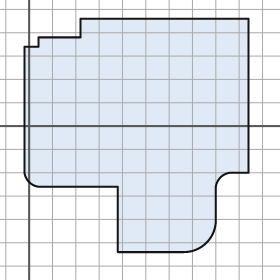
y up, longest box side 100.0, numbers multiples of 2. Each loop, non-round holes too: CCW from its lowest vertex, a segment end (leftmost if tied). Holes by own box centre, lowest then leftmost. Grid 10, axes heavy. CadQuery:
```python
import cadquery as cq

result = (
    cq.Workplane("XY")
    .moveTo(38.0, -54.0)
    .lineTo(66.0, -54.0)
    .threePointArc((76.0, -50.0), (80.0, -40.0))
    .lineTo(80.0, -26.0)
    .threePointArc((82.0, -22.0), (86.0, -20.0))
    .lineTo(94.0, -20.0)
    .lineTo(94.0, 46.0)
    .lineTo(22.0, 46.0)
    .lineTo(22.0, 38.0)
    .lineTo(4.0, 38.0)
    .lineTo(4.0, 34.0)
    .lineTo(-2.0, 34.0)
    .lineTo(-2.0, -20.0)
    .threePointArc((0.0, -24.0), (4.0, -26.0))
    .lineTo(38.0, -26.0)
    .close()
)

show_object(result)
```